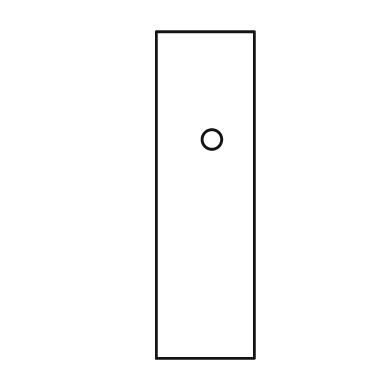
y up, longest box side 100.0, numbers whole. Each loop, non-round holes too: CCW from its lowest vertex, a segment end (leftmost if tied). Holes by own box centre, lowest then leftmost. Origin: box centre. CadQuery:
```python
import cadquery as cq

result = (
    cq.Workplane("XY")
    .moveTo(-15.0, -50.0)
    .lineTo(15.0, -50.0)
    .lineTo(15.0, 50.0)
    .lineTo(-15.0, 50.0)
    .close()
    .moveTo(2.0, 17.0)
    .circle(3.0)
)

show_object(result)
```